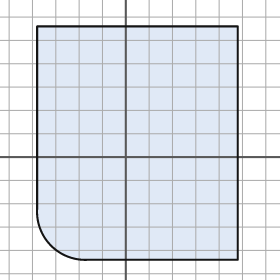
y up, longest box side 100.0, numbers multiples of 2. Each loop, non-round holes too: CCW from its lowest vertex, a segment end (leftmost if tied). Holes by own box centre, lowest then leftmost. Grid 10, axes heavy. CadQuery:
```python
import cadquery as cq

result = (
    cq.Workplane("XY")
    .moveTo(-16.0, -44.0)
    .lineTo(48.0, -44.0)
    .lineTo(48.0, 56.0)
    .lineTo(-38.0, 56.0)
    .lineTo(-38.0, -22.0)
    .threePointArc((-32.0, -38.0), (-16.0, -44.0))
    .close()
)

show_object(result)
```